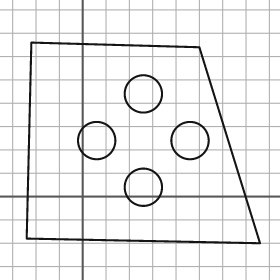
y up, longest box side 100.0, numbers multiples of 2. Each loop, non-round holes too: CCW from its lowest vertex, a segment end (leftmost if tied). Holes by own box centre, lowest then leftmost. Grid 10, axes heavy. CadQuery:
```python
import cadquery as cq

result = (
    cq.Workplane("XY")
    .moveTo(76.0, -20.0)
    .lineTo(50.0, 64.0)
    .lineTo(-22.0, 66.0)
    .lineTo(-24.0, -18.0)
    .close()
    .moveTo(26.0, 4.0)
    .circle(8.0)
    .moveTo(6.0, 24.0)
    .circle(8.0)
    .moveTo(46.0, 24.0)
    .circle(8.0)
    .moveTo(26.0, 44.0)
    .circle(8.0)
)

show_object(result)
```